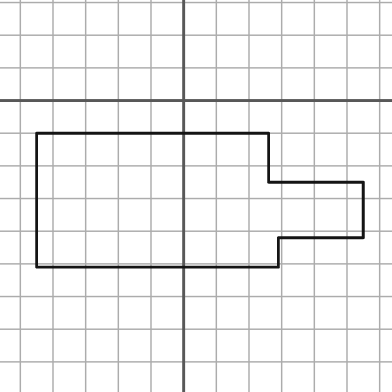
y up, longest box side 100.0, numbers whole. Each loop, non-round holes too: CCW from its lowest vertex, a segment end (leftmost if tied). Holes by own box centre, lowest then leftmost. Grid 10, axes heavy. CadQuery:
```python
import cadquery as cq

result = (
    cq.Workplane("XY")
    .moveTo(-45.0, -51.0)
    .lineTo(29.0, -51.0)
    .lineTo(29.0, -42.0)
    .lineTo(55.0, -42.0)
    .lineTo(55.0, -25.0)
    .lineTo(26.0, -25.0)
    .lineTo(26.0, -10.0)
    .lineTo(-45.0, -10.0)
    .close()
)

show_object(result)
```